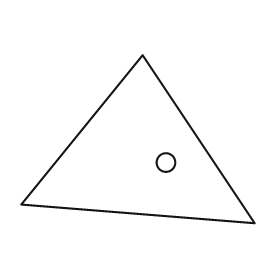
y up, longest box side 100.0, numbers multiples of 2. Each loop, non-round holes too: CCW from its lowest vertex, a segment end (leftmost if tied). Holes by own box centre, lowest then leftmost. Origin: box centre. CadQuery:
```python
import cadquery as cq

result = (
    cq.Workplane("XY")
    .moveTo(50.0, -36.0)
    .lineTo(2.0, 36.0)
    .lineTo(-50.0, -28.0)
    .close()
    .moveTo(12.0, -10.0)
    .circle(4.0)
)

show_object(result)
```